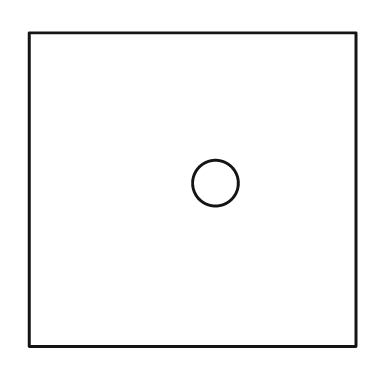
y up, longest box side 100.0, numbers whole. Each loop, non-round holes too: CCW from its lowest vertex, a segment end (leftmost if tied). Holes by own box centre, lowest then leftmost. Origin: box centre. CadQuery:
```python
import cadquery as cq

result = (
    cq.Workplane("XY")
    .moveTo(-50.0, -48.0)
    .lineTo(50.0, -48.0)
    .lineTo(50.0, 48.0)
    .lineTo(-50.0, 48.0)
    .close()
    .moveTo(7.0, 2.0)
    .circle(7.0)
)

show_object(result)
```